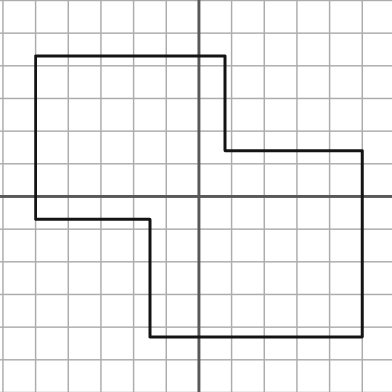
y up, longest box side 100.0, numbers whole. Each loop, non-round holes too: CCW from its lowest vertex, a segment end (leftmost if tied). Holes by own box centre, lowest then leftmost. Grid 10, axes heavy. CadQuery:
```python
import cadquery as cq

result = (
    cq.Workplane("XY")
    .moveTo(-15.0, -43.0)
    .lineTo(50.0, -43.0)
    .lineTo(50.0, 14.0)
    .lineTo(8.0, 14.0)
    .lineTo(8.0, 43.0)
    .lineTo(-50.0, 43.0)
    .lineTo(-50.0, -7.0)
    .lineTo(-15.0, -7.0)
    .close()
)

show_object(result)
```